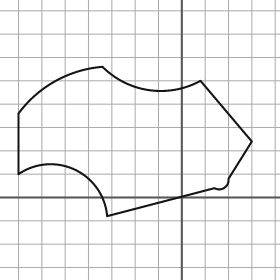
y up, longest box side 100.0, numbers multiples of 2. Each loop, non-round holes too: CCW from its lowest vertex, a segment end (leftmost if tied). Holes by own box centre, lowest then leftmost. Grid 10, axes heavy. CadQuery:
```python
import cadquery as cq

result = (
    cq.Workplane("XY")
    .moveTo(-32.0, -8.0)
    .lineTo(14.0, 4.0)
    .threePointArc((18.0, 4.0), (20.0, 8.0))
    .lineTo(30.0, 24.0)
    .lineTo(8.0, 50.0)
    .threePointArc((-14.0, 46.0), (-34.0, 56.0))
    .threePointArc((-54.0, 50.0), (-70.0, 36.0))
    .lineTo(-70.0, 10.0)
    .threePointArc((-46.0, 12.0), (-32.0, -8.0))
    .close()
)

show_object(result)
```